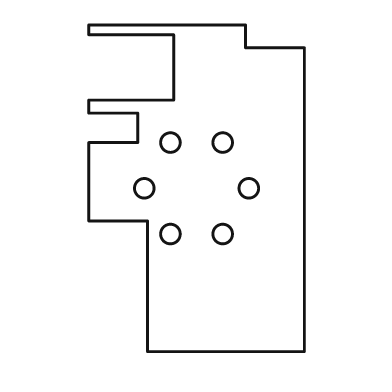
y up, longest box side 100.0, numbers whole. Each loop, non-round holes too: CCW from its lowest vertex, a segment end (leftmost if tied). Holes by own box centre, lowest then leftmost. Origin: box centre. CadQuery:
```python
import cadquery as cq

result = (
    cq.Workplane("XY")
    .moveTo(-15.0, -50.0)
    .lineTo(33.0, -50.0)
    .lineTo(33.0, 43.0)
    .lineTo(15.0, 43.0)
    .lineTo(15.0, 50.0)
    .lineTo(-33.0, 50.0)
    .lineTo(-33.0, 47.0)
    .lineTo(-7.0, 47.0)
    .lineTo(-7.0, 27.0)
    .lineTo(-33.0, 27.0)
    .lineTo(-33.0, 23.0)
    .lineTo(-18.0, 23.0)
    .lineTo(-18.0, 14.0)
    .lineTo(-33.0, 14.0)
    .lineTo(-33.0, -10.0)
    .lineTo(-15.0, -10.0)
    .close()
    .moveTo(-8.0, -14.0)
    .circle(3.0)
    .moveTo(8.0, -14.0)
    .circle(3.0)
    .moveTo(-16.0, 0.0)
    .circle(3.0)
    .moveTo(16.0, 0.0)
    .circle(3.0)
    .moveTo(-8.0, 14.0)
    .circle(3.0)
    .moveTo(8.0, 14.0)
    .circle(3.0)
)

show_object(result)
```